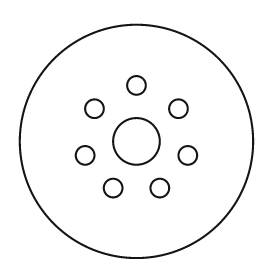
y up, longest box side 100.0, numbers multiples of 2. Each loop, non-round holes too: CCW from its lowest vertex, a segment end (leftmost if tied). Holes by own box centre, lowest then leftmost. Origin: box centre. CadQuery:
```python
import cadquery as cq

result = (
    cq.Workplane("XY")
    .moveTo(0.0, 0.0)
    .circle(50.0)
    .moveTo(-10.0, -20.0)
    .circle(4.0)
    .moveTo(10.0, -20.0)
    .circle(4.0)
    .moveTo(-22.0, -6.0)
    .circle(4.0)
    .moveTo(22.0, -6.0)
    .circle(4.0)
    .moveTo(0.0, 0.0)
    .circle(10.0)
    .moveTo(-18.0, 14.0)
    .circle(4.0)
    .moveTo(18.0, 14.0)
    .circle(4.0)
    .moveTo(0.0, 24.0)
    .circle(4.0)
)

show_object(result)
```